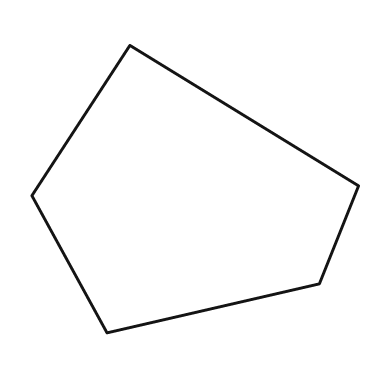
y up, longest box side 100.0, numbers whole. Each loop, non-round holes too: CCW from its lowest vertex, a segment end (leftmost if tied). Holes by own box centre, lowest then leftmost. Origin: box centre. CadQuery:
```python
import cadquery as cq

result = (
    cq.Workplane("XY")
    .moveTo(-27.0, -44.0)
    .lineTo(38.0, -29.0)
    .lineTo(50.0, 1.0)
    .lineTo(-20.0, 44.0)
    .lineTo(-50.0, -2.0)
    .close()
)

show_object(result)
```